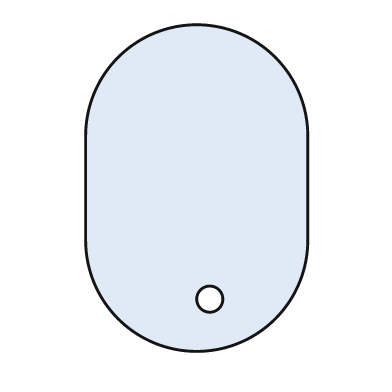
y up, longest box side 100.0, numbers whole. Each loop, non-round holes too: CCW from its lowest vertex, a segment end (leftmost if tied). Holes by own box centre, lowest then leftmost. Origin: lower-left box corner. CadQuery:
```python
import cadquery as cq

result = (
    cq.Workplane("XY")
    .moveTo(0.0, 34.0)
    .threePointArc((34.0, 0.0), (68.0, 34.0))
    .lineTo(68.0, 66.0)
    .threePointArc((34.0, 100.0), (0.0, 66.0))
    .close()
    .moveTo(38.0, 16.0)
    .circle(4.0)
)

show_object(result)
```